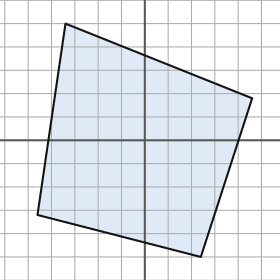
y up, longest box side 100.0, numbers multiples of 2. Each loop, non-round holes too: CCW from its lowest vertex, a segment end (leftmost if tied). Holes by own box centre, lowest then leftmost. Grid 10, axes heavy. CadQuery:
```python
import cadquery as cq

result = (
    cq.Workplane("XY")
    .moveTo(24.0, -50.0)
    .lineTo(46.0, 18.0)
    .lineTo(-34.0, 50.0)
    .lineTo(-46.0, -32.0)
    .close()
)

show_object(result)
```